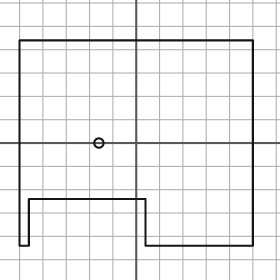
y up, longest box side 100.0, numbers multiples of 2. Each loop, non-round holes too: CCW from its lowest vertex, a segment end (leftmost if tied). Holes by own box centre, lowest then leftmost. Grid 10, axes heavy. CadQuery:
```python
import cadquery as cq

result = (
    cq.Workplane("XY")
    .moveTo(-50.0, -44.0)
    .lineTo(-46.0, -44.0)
    .lineTo(-46.0, -24.0)
    .lineTo(4.0, -24.0)
    .lineTo(4.0, -44.0)
    .lineTo(50.0, -44.0)
    .lineTo(50.0, 44.0)
    .lineTo(-50.0, 44.0)
    .close()
    .moveTo(-16.0, 0.0)
    .circle(2.0)
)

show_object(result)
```